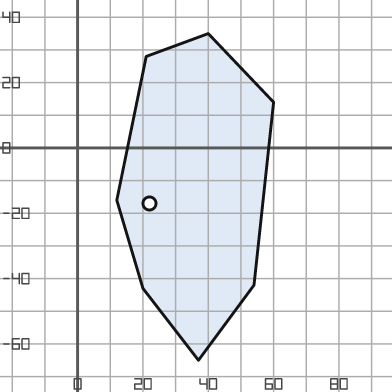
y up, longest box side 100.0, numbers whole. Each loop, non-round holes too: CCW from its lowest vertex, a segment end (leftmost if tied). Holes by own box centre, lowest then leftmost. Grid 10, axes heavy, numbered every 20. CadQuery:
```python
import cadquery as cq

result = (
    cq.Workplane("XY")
    .moveTo(37.0, -65.0)
    .lineTo(54.0, -42.0)
    .lineTo(60.0, 14.0)
    .lineTo(40.0, 35.0)
    .lineTo(21.0, 28.0)
    .lineTo(12.0, -16.0)
    .lineTo(20.0, -43.0)
    .close()
    .moveTo(22.0, -17.0)
    .circle(2.0)
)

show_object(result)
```